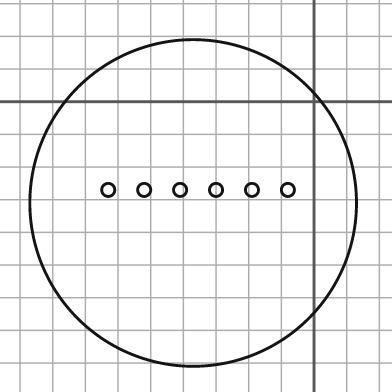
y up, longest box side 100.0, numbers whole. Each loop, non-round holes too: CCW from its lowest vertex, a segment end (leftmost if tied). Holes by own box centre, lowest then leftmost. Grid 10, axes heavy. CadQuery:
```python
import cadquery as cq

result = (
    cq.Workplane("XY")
    .moveTo(-37.0, -31.0)
    .circle(50.0)
    .moveTo(-63.0, -27.0)
    .circle(2.0)
    .moveTo(-52.0, -27.0)
    .circle(2.0)
    .moveTo(-41.0, -27.0)
    .circle(2.0)
    .moveTo(-30.0, -27.0)
    .circle(2.0)
    .moveTo(-19.0, -27.0)
    .circle(2.0)
    .moveTo(-8.0, -27.0)
    .circle(2.0)
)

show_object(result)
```